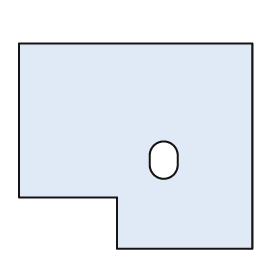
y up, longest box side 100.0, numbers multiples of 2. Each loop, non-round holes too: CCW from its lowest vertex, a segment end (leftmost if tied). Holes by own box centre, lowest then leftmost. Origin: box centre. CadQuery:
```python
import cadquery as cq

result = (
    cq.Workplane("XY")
    .moveTo(-8.0, -44.0)
    .lineTo(50.0, -44.0)
    .lineTo(50.0, 44.0)
    .lineTo(-50.0, 44.0)
    .lineTo(-50.0, -22.0)
    .lineTo(-8.0, -22.0)
    .close()
    .moveTo(6.0, -8.0)
    .threePointArc((12.0, -14.0), (18.0, -8.0))
    .lineTo(18.0, -4.0)
    .threePointArc((12.0, 2.0), (6.0, -4.0))
    .close()
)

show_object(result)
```